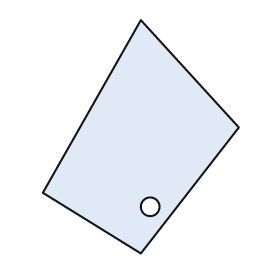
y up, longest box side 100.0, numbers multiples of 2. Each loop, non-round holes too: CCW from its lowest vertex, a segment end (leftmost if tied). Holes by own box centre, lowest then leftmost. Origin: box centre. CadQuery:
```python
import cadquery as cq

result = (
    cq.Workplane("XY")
    .moveTo(0.0, -50.0)
    .lineTo(42.0, 4.0)
    .lineTo(0.0, 50.0)
    .lineTo(-42.0, -24.0)
    .close()
    .moveTo(4.0, -30.0)
    .circle(4.0)
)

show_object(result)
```